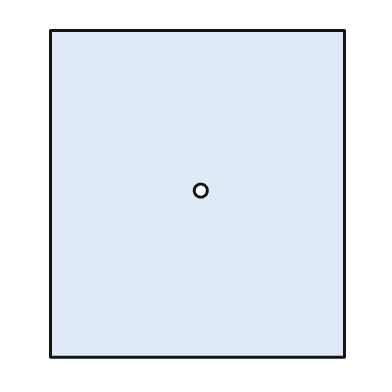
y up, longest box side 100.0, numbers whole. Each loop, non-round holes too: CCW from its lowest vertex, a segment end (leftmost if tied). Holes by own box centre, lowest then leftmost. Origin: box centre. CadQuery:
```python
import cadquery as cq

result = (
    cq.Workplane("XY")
    .moveTo(-45.0, -50.0)
    .lineTo(45.0, -50.0)
    .lineTo(45.0, 50.0)
    .lineTo(-45.0, 50.0)
    .close()
    .moveTo(1.0, 1.0)
    .circle(2.0)
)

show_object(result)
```